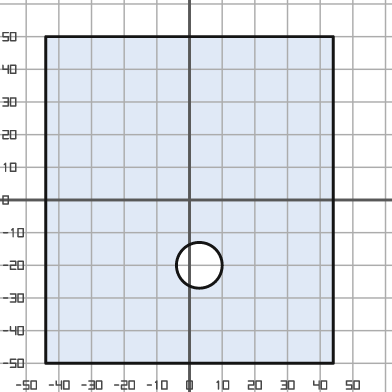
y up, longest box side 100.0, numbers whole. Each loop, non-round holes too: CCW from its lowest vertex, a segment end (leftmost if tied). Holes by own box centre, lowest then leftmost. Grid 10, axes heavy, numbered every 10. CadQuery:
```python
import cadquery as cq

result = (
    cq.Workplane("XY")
    .moveTo(-44.0, -50.0)
    .lineTo(44.0, -50.0)
    .lineTo(44.0, 50.0)
    .lineTo(-44.0, 50.0)
    .close()
    .moveTo(3.0, -20.0)
    .circle(7.0)
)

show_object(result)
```